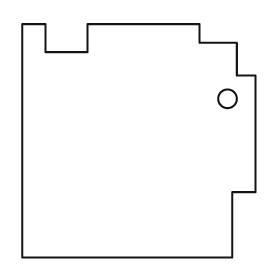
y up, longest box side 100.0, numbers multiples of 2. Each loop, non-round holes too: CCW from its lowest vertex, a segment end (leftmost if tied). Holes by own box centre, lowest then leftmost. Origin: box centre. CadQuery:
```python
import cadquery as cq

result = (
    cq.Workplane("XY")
    .moveTo(-50.0, -50.0)
    .lineTo(40.0, -50.0)
    .lineTo(40.0, -22.0)
    .lineTo(50.0, -22.0)
    .lineTo(50.0, 28.0)
    .lineTo(42.0, 28.0)
    .lineTo(42.0, 42.0)
    .lineTo(26.0, 42.0)
    .lineTo(26.0, 50.0)
    .lineTo(-22.0, 50.0)
    .lineTo(-22.0, 38.0)
    .lineTo(-40.0, 38.0)
    .lineTo(-40.0, 50.0)
    .lineTo(-50.0, 50.0)
    .close()
    .moveTo(38.0, 18.0)
    .circle(4.0)
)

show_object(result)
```